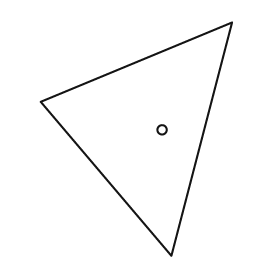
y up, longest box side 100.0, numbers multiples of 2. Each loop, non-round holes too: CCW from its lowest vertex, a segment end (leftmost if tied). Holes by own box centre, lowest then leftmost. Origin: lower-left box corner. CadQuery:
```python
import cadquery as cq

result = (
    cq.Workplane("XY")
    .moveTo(56.0, 0.0)
    .lineTo(82.0, 100.0)
    .lineTo(0.0, 66.0)
    .close()
    .moveTo(52.0, 54.0)
    .circle(2.0)
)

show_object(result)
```